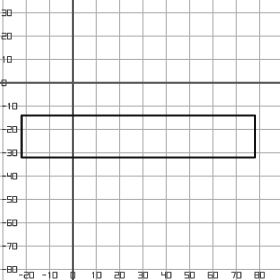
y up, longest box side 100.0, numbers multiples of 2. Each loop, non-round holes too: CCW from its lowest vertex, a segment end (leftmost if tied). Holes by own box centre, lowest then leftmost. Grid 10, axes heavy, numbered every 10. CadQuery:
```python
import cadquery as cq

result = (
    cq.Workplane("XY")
    .moveTo(-22.0, -32.0)
    .lineTo(78.0, -32.0)
    .lineTo(78.0, -14.0)
    .lineTo(-22.0, -14.0)
    .close()
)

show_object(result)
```